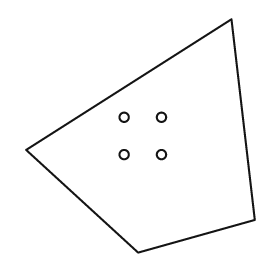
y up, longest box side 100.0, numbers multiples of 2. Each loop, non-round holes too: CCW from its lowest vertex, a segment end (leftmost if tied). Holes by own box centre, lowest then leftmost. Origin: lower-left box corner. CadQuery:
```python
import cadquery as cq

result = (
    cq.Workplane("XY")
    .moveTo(48.0, 0.0)
    .lineTo(98.0, 14.0)
    .lineTo(88.0, 100.0)
    .lineTo(0.0, 44.0)
    .close()
    .moveTo(42.0, 42.0)
    .circle(2.0)
    .moveTo(58.0, 42.0)
    .circle(2.0)
    .moveTo(42.0, 58.0)
    .circle(2.0)
    .moveTo(58.0, 58.0)
    .circle(2.0)
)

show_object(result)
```